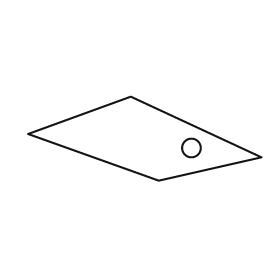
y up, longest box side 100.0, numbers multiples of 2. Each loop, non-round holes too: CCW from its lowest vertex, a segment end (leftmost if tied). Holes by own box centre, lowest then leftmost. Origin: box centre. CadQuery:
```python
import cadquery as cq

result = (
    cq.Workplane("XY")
    .moveTo(6.0, -18.0)
    .lineTo(50.0, -8.0)
    .lineTo(-6.0, 18.0)
    .lineTo(-50.0, 2.0)
    .close()
    .moveTo(20.0, -4.0)
    .circle(4.0)
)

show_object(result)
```